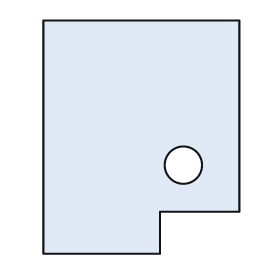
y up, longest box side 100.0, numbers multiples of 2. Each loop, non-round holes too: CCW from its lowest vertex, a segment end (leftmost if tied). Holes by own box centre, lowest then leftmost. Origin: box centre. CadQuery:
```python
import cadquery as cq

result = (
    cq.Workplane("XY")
    .moveTo(-42.0, -50.0)
    .lineTo(8.0, -50.0)
    .lineTo(8.0, -32.0)
    .lineTo(42.0, -32.0)
    .lineTo(42.0, 50.0)
    .lineTo(-42.0, 50.0)
    .close()
    .moveTo(18.0, -12.0)
    .circle(8.0)
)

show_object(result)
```